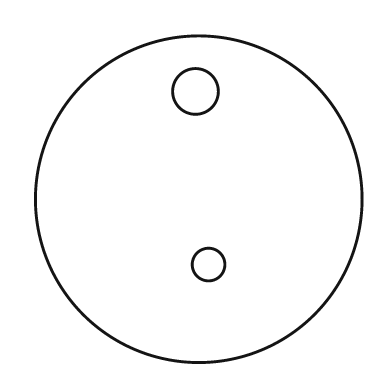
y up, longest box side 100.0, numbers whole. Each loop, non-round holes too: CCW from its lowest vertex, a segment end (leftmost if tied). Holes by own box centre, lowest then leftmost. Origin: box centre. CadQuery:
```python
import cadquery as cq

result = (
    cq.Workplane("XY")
    .moveTo(0.0, 0.0)
    .circle(50.0)
    .moveTo(3.0, -20.0)
    .circle(5.0)
    .moveTo(-1.0, 33.0)
    .circle(7.0)
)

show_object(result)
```